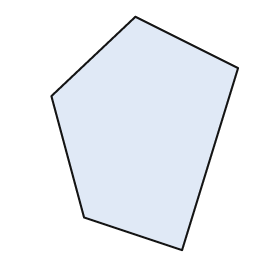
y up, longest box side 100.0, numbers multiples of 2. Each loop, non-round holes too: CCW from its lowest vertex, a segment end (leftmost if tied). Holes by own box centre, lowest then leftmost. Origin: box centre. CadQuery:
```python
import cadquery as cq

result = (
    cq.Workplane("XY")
    .moveTo(16.0, -50.0)
    .lineTo(40.0, 28.0)
    .lineTo(-4.0, 50.0)
    .lineTo(-40.0, 16.0)
    .lineTo(-26.0, -36.0)
    .close()
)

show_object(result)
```